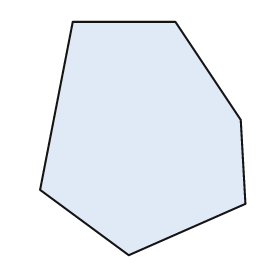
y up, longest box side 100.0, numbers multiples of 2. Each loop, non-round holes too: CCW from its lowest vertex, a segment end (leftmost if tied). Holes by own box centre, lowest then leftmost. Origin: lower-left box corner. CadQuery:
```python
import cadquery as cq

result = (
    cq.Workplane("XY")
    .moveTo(38.0, 0.0)
    .lineTo(88.0, 22.0)
    .lineTo(86.0, 58.0)
    .lineTo(58.0, 100.0)
    .lineTo(14.0, 100.0)
    .lineTo(0.0, 28.0)
    .close()
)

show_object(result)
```